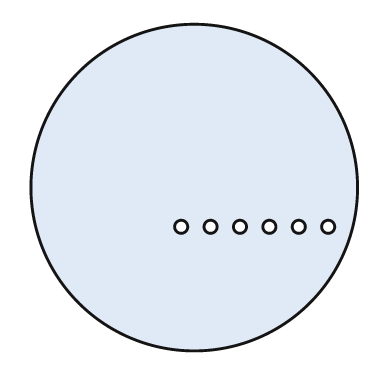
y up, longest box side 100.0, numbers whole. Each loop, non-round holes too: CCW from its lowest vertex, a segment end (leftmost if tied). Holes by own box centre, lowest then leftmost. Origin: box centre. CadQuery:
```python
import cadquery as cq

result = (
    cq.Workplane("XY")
    .moveTo(0.0, 0.0)
    .circle(50.0)
    .moveTo(-4.0, -12.0)
    .circle(2.0)
    .moveTo(5.0, -12.0)
    .circle(2.0)
    .moveTo(14.0, -12.0)
    .circle(2.0)
    .moveTo(23.0, -12.0)
    .circle(2.0)
    .moveTo(32.0, -12.0)
    .circle(2.0)
    .moveTo(41.0, -12.0)
    .circle(2.0)
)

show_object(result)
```